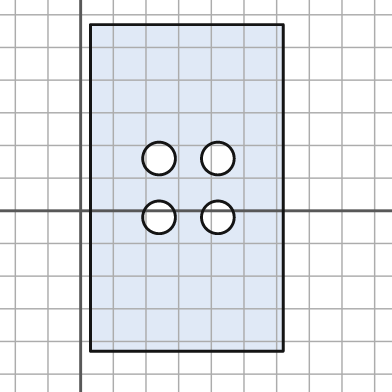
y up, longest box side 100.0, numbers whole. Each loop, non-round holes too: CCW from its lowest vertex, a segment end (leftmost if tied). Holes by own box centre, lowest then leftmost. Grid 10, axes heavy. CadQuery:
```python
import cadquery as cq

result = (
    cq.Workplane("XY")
    .moveTo(3.0, -43.0)
    .lineTo(62.0, -43.0)
    .lineTo(62.0, 57.0)
    .lineTo(3.0, 57.0)
    .close()
    .moveTo(24.0, -2.0)
    .circle(5.0)
    .moveTo(42.0, -2.0)
    .circle(5.0)
    .moveTo(24.0, 16.0)
    .circle(5.0)
    .moveTo(42.0, 16.0)
    .circle(5.0)
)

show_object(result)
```